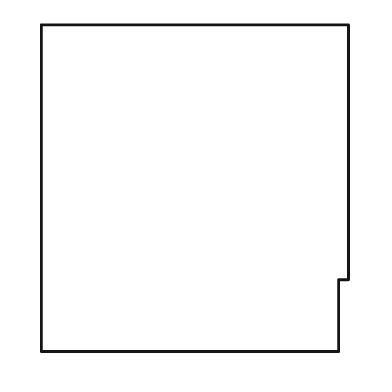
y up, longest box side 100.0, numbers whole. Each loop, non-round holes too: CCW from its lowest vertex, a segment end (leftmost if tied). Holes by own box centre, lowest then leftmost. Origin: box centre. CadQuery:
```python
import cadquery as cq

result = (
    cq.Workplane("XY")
    .moveTo(-47.0, -50.0)
    .lineTo(44.0, -50.0)
    .lineTo(44.0, -28.0)
    .lineTo(47.0, -28.0)
    .lineTo(47.0, 50.0)
    .lineTo(-47.0, 50.0)
    .close()
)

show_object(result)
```